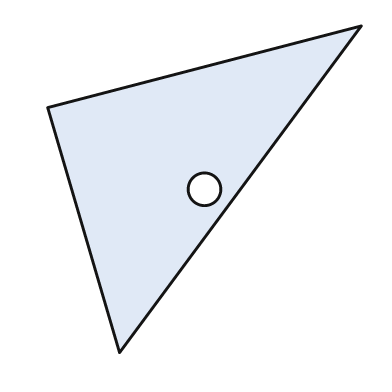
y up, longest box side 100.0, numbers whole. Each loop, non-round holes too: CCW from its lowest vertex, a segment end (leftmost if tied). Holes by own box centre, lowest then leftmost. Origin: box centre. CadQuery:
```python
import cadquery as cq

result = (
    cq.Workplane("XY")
    .moveTo(-26.0, -50.0)
    .lineTo(48.0, 50.0)
    .lineTo(-48.0, 25.0)
    .close()
    .moveTo(0.0, 0.0)
    .circle(5.0)
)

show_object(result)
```